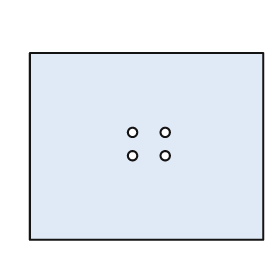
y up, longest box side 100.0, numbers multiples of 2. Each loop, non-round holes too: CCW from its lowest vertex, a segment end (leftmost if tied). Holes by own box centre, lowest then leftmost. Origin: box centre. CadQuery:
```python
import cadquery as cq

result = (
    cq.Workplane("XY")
    .moveTo(-50.0, -40.0)
    .lineTo(50.0, -40.0)
    .lineTo(50.0, 40.0)
    .lineTo(-50.0, 40.0)
    .close()
    .moveTo(-6.0, -4.0)
    .circle(2.0)
    .moveTo(8.0, -4.0)
    .circle(2.0)
    .moveTo(-6.0, 6.0)
    .circle(2.0)
    .moveTo(8.0, 6.0)
    .circle(2.0)
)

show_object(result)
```